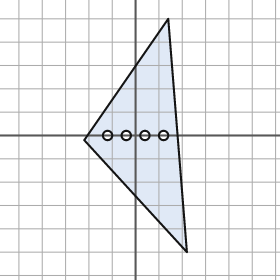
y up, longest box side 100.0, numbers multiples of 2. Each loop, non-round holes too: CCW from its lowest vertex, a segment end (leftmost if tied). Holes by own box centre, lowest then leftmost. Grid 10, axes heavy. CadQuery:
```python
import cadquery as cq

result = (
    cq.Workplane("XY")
    .moveTo(22.0, -50.0)
    .lineTo(14.0, 50.0)
    .lineTo(-22.0, -2.0)
    .close()
    .moveTo(-12.0, 0.0)
    .circle(2.0)
    .moveTo(-4.0, 0.0)
    .circle(2.0)
    .moveTo(4.0, 0.0)
    .circle(2.0)
    .moveTo(12.0, 0.0)
    .circle(2.0)
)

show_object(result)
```